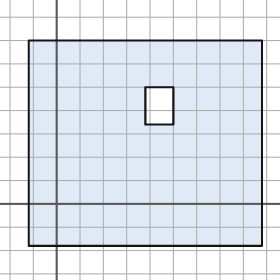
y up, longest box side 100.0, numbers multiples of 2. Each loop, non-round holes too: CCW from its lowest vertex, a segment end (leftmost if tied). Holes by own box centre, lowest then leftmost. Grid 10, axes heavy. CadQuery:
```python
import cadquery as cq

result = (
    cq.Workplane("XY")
    .moveTo(-12.0, -18.0)
    .lineTo(88.0, -18.0)
    .lineTo(88.0, 70.0)
    .lineTo(-12.0, 70.0)
    .close()
    .moveTo(38.0, 34.0)
    .lineTo(50.0, 34.0)
    .lineTo(50.0, 50.0)
    .lineTo(38.0, 50.0)
    .close()
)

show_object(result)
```